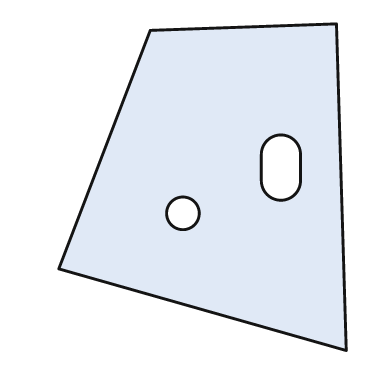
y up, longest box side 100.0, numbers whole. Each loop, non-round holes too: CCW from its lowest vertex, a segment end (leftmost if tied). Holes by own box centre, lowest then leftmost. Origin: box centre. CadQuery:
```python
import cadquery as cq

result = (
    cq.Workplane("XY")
    .moveTo(44.0, -50.0)
    .lineTo(41.0, 50.0)
    .lineTo(-16.0, 48.0)
    .lineTo(-44.0, -25.0)
    .close()
    .moveTo(-6.0, -8.0)
    .circle(5.0)
    .moveTo(18.0, 2.0)
    .threePointArc((24.0, -4.0), (30.0, 2.0))
    .lineTo(30.0, 10.0)
    .threePointArc((24.0, 16.0), (18.0, 10.0))
    .close()
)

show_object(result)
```